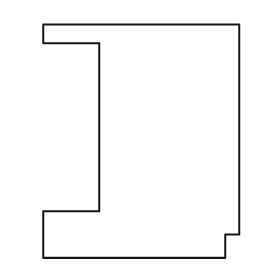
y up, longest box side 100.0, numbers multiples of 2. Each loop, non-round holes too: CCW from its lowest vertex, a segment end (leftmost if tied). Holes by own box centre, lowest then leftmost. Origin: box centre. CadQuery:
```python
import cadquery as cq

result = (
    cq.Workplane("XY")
    .moveTo(-42.0, -50.0)
    .lineTo(36.0, -50.0)
    .lineTo(36.0, -40.0)
    .lineTo(42.0, -40.0)
    .lineTo(42.0, 50.0)
    .lineTo(-42.0, 50.0)
    .lineTo(-42.0, 42.0)
    .lineTo(-18.0, 42.0)
    .lineTo(-18.0, -30.0)
    .lineTo(-42.0, -30.0)
    .close()
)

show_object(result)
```